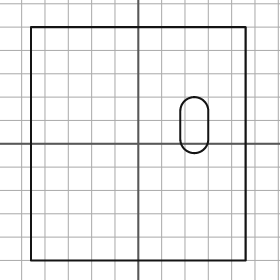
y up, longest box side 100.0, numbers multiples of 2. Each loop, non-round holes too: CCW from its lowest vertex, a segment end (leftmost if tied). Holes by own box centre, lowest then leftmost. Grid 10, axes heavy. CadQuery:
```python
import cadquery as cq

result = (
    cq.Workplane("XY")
    .moveTo(-46.0, -50.0)
    .lineTo(46.0, -50.0)
    .lineTo(46.0, 50.0)
    .lineTo(-46.0, 50.0)
    .close()
    .moveTo(18.0, 2.0)
    .threePointArc((24.0, -4.0), (30.0, 2.0))
    .lineTo(30.0, 14.0)
    .threePointArc((24.0, 20.0), (18.0, 14.0))
    .close()
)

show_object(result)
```